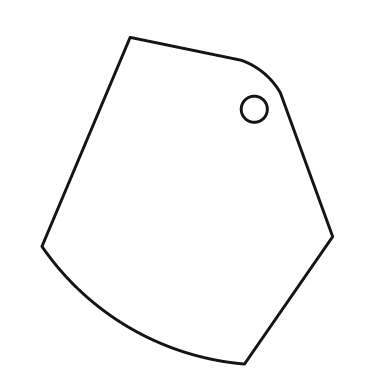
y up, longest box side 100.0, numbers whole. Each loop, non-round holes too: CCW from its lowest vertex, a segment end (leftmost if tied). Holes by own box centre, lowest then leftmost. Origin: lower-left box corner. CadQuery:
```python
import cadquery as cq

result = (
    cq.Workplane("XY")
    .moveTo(62.0, 0.0)
    .lineTo(89.0, 39.0)
    .lineTo(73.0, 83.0)
    .threePointArc((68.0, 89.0), (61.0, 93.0))
    .lineTo(27.0, 100.0)
    .lineTo(0.0, 36.0)
    .threePointArc((27.0, 11.0), (62.0, 0.0))
    .close()
    .moveTo(65.0, 78.0)
    .circle(4.0)
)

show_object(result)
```